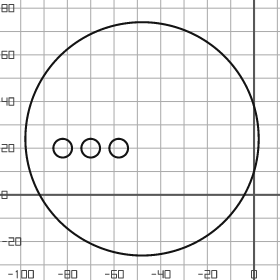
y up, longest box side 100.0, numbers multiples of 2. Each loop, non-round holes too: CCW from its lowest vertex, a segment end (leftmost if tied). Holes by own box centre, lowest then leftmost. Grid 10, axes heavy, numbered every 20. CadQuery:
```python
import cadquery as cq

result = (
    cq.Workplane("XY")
    .moveTo(-48.0, 24.0)
    .circle(50.0)
    .moveTo(-82.0, 20.0)
    .circle(4.0)
    .moveTo(-70.0, 20.0)
    .circle(4.0)
    .moveTo(-58.0, 20.0)
    .circle(4.0)
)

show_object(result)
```